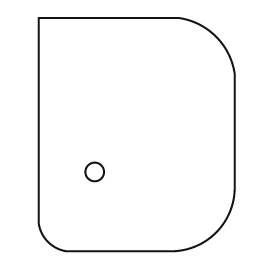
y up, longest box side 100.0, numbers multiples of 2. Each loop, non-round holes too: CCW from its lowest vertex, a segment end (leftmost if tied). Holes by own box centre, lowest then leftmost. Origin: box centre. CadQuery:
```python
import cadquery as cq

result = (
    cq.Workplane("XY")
    .moveTo(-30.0, -50.0)
    .lineTo(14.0, -50.0)
    .threePointArc((34.0, -42.0), (42.0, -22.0))
    .lineTo(42.0, 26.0)
    .threePointArc((34.0, 42.0), (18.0, 50.0))
    .lineTo(-42.0, 50.0)
    .lineTo(-42.0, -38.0)
    .threePointArc((-38.0, -46.0), (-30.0, -50.0))
    .close()
    .moveTo(-18.0, -16.0)
    .circle(4.0)
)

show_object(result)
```